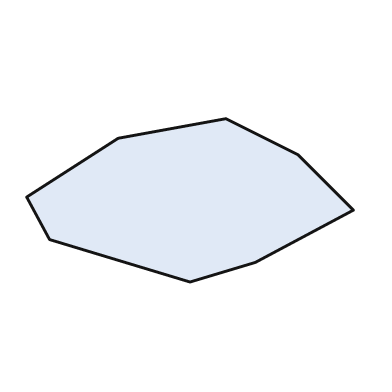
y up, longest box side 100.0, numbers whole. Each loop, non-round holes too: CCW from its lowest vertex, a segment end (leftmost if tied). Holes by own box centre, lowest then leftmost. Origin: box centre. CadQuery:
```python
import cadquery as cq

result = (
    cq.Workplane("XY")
    .moveTo(0.0, -25.0)
    .lineTo(20.0, -19.0)
    .lineTo(50.0, -3.0)
    .lineTo(33.0, 14.0)
    .lineTo(11.0, 25.0)
    .lineTo(-22.0, 19.0)
    .lineTo(-50.0, 1.0)
    .lineTo(-43.0, -12.0)
    .close()
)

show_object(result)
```